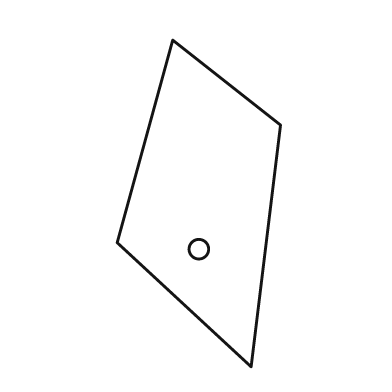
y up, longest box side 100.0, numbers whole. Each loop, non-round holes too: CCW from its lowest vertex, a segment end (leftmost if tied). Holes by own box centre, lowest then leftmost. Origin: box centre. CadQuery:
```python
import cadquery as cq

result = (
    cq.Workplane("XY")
    .moveTo(16.0, -50.0)
    .lineTo(25.0, 24.0)
    .lineTo(-8.0, 50.0)
    .lineTo(-25.0, -12.0)
    .close()
    .moveTo(0.0, -14.0)
    .circle(3.0)
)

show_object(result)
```